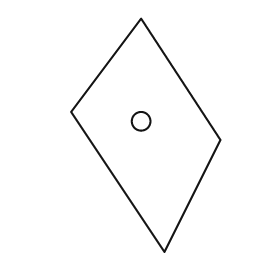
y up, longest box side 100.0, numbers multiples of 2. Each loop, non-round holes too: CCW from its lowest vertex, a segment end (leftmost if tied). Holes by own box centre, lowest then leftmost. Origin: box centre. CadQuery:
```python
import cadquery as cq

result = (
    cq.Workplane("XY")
    .moveTo(8.0, -50.0)
    .lineTo(32.0, -2.0)
    .lineTo(-2.0, 50.0)
    .lineTo(-32.0, 10.0)
    .close()
    .moveTo(-2.0, 6.0)
    .circle(4.0)
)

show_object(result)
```